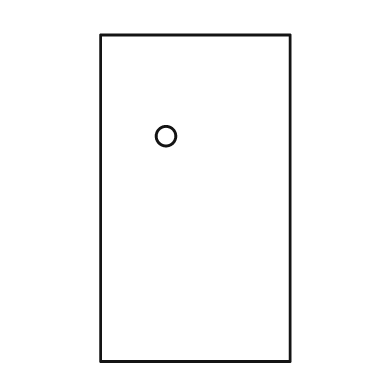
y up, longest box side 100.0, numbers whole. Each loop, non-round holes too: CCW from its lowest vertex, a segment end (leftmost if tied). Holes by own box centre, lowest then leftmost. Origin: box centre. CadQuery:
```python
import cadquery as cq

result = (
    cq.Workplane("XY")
    .moveTo(-29.0, -50.0)
    .lineTo(29.0, -50.0)
    .lineTo(29.0, 50.0)
    .lineTo(-29.0, 50.0)
    .close()
    .moveTo(-9.0, 19.0)
    .circle(3.0)
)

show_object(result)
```